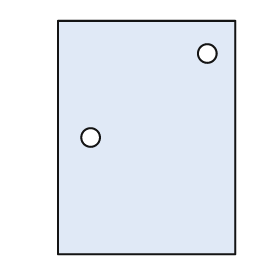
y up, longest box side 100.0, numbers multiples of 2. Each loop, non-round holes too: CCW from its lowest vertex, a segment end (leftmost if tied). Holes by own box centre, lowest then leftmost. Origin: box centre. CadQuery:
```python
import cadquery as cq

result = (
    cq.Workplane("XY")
    .moveTo(-38.0, -50.0)
    .lineTo(38.0, -50.0)
    .lineTo(38.0, 50.0)
    .lineTo(-38.0, 50.0)
    .close()
    .moveTo(-24.0, 0.0)
    .circle(4.0)
    .moveTo(26.0, 36.0)
    .circle(4.0)
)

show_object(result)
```